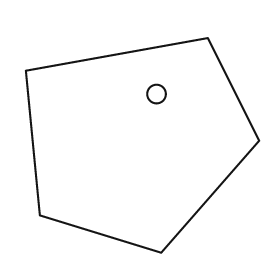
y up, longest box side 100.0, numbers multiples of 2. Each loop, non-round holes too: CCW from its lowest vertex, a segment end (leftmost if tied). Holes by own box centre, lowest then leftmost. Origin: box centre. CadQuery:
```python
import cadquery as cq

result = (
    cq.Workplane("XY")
    .moveTo(8.0, -46.0)
    .lineTo(50.0, 2.0)
    .lineTo(28.0, 46.0)
    .lineTo(-50.0, 32.0)
    .lineTo(-44.0, -30.0)
    .close()
    .moveTo(6.0, 22.0)
    .circle(4.0)
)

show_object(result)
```